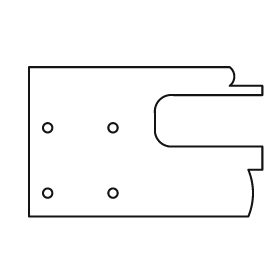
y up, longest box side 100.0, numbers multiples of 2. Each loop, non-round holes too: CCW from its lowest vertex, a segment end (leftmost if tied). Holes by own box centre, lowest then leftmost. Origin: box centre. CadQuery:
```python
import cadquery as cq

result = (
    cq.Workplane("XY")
    .moveTo(-50.0, -32.0)
    .lineTo(44.0, -32.0)
    .threePointArc((46.0, -22.0), (44.0, -12.0))
    .lineTo(50.0, -12.0)
    .lineTo(50.0, -2.0)
    .lineTo(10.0, -2.0)
    .threePointArc((6.0, 0.0), (4.0, 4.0))
    .lineTo(4.0, 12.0)
    .threePointArc((6.0, 18.0), (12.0, 20.0))
    .lineTo(50.0, 20.0)
    .lineTo(50.0, 24.0)
    .lineTo(36.0, 24.0)
    .threePointArc((38.0, 28.0), (36.0, 32.0))
    .lineTo(-50.0, 32.0)
    .close()
    .moveTo(-42.0, -22.0)
    .circle(2.0)
    .moveTo(-14.0, -22.0)
    .circle(2.0)
    .moveTo(-42.0, 6.0)
    .circle(2.0)
    .moveTo(-14.0, 6.0)
    .circle(2.0)
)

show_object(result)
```